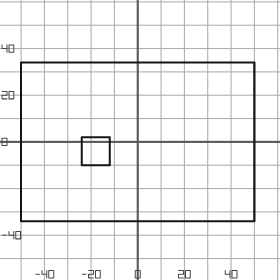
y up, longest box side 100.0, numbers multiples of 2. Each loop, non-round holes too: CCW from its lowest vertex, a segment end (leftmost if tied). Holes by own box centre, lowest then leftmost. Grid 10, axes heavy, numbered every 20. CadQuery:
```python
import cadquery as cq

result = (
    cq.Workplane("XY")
    .moveTo(-50.0, -34.0)
    .lineTo(50.0, -34.0)
    .lineTo(50.0, 34.0)
    .lineTo(-50.0, 34.0)
    .close()
    .moveTo(-24.0, -10.0)
    .lineTo(-12.0, -10.0)
    .lineTo(-12.0, 2.0)
    .lineTo(-24.0, 2.0)
    .close()
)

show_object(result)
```